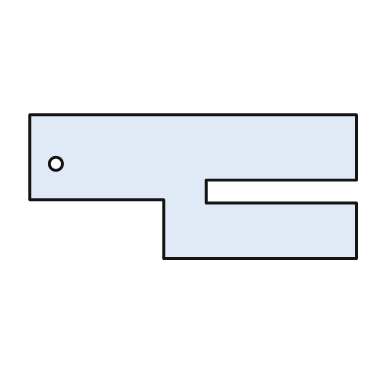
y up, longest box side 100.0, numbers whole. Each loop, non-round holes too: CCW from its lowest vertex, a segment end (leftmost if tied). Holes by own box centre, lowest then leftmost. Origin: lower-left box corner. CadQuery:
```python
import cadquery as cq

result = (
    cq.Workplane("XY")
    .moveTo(41.0, 0.0)
    .lineTo(100.0, 0.0)
    .lineTo(100.0, 17.0)
    .lineTo(54.0, 17.0)
    .lineTo(54.0, 24.0)
    .lineTo(100.0, 24.0)
    .lineTo(100.0, 44.0)
    .lineTo(0.0, 44.0)
    .lineTo(0.0, 18.0)
    .lineTo(41.0, 18.0)
    .close()
    .moveTo(8.0, 29.0)
    .circle(2.0)
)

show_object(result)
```